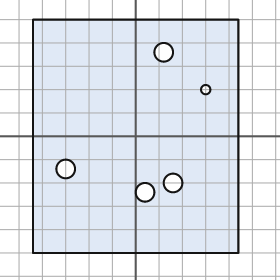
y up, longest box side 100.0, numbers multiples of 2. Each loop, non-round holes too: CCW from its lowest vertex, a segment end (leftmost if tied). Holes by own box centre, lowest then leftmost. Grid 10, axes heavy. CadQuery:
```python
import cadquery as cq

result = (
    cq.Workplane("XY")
    .moveTo(-44.0, -50.0)
    .lineTo(44.0, -50.0)
    .lineTo(44.0, 50.0)
    .lineTo(-44.0, 50.0)
    .close()
    .moveTo(4.0, -24.0)
    .circle(4.0)
    .moveTo(16.0, -20.0)
    .circle(4.0)
    .moveTo(-30.0, -14.0)
    .circle(4.0)
    .moveTo(30.0, 20.0)
    .circle(2.0)
    .moveTo(12.0, 36.0)
    .circle(4.0)
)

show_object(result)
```